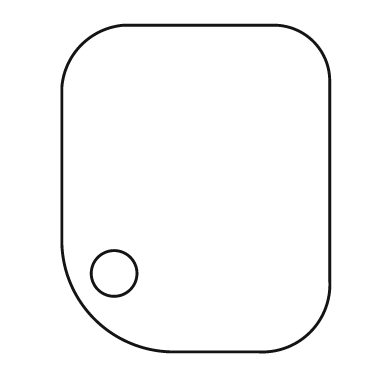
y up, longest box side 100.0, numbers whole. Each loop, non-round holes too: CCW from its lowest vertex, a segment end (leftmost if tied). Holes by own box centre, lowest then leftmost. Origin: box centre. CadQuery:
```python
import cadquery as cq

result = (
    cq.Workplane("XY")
    .moveTo(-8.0, -50.0)
    .lineTo(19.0, -50.0)
    .threePointArc((35.0, -44.0), (41.0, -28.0))
    .lineTo(41.0, 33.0)
    .threePointArc((36.0, 45.0), (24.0, 50.0))
    .lineTo(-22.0, 50.0)
    .threePointArc((-35.0, 44.0), (-41.0, 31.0))
    .lineTo(-41.0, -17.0)
    .threePointArc((-31.0, -40.0), (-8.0, -50.0))
    .close()
    .moveTo(-25.0, -26.0)
    .circle(7.0)
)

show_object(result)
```